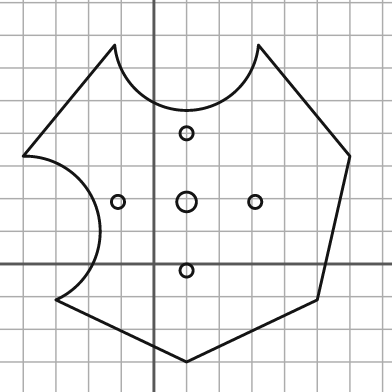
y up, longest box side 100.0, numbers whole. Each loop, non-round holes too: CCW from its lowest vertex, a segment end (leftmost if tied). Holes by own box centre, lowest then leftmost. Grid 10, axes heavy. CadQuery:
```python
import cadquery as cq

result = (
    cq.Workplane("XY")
    .moveTo(10.0, -30.0)
    .lineTo(50.0, -11.0)
    .lineTo(60.0, 33.0)
    .lineTo(32.0, 67.0)
    .threePointArc((10.0, 47.0), (-12.0, 67.0))
    .lineTo(-40.0, 33.0)
    .threePointArc((-17.0, 15.0), (-30.0, -11.0))
    .close()
    .moveTo(10.0, -2.0)
    .circle(2.0)
    .moveTo(-11.0, 19.0)
    .circle(2.0)
    .moveTo(10.0, 19.0)
    .circle(3.0)
    .moveTo(31.0, 19.0)
    .circle(2.0)
    .moveTo(10.0, 40.0)
    .circle(2.0)
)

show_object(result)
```